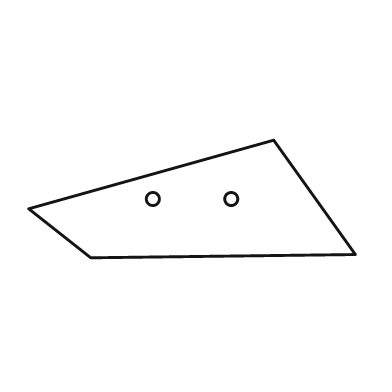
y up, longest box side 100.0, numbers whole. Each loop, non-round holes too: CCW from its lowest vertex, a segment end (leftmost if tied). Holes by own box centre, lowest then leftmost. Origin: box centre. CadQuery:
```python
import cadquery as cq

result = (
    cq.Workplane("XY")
    .moveTo(-31.0, -18.0)
    .lineTo(50.0, -17.0)
    .lineTo(25.0, 18.0)
    .lineTo(-50.0, -3.0)
    .close()
    .moveTo(-12.0, 0.0)
    .circle(2.0)
    .moveTo(12.0, 0.0)
    .circle(2.0)
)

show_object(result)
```